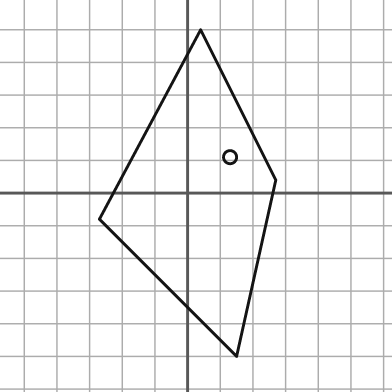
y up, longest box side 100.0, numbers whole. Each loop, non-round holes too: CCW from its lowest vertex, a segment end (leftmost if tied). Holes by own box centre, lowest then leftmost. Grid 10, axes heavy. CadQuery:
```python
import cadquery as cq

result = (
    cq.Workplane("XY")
    .moveTo(15.0, -50.0)
    .lineTo(27.0, 4.0)
    .lineTo(4.0, 50.0)
    .lineTo(-27.0, -8.0)
    .close()
    .moveTo(13.0, 11.0)
    .circle(2.0)
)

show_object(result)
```